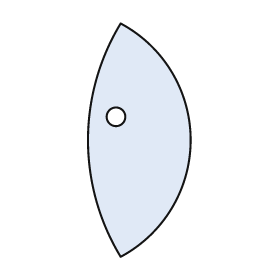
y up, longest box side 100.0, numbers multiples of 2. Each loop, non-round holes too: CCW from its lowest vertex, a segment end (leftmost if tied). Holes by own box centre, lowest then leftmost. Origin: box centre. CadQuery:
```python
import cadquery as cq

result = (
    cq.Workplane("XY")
    .moveTo(-8.0, -50.0)
    .threePointArc((22.0, 0.0), (-8.0, 50.0))
    .threePointArc((-22.0, 0.0), (-8.0, -50.0))
    .close()
    .moveTo(-10.0, 10.0)
    .circle(4.0)
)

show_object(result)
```